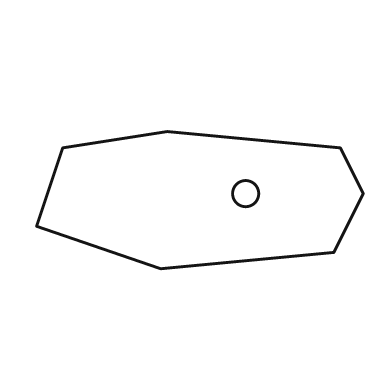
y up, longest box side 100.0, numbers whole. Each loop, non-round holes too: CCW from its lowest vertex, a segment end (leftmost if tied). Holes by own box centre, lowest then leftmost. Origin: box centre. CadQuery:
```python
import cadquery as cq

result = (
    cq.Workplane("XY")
    .moveTo(-12.0, -21.0)
    .lineTo(41.0, -16.0)
    .lineTo(50.0, 2.0)
    .lineTo(43.0, 16.0)
    .lineTo(-10.0, 21.0)
    .lineTo(-42.0, 16.0)
    .lineTo(-50.0, -8.0)
    .close()
    .moveTo(14.0, 2.0)
    .circle(4.0)
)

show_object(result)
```